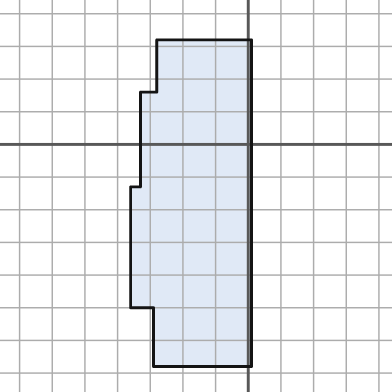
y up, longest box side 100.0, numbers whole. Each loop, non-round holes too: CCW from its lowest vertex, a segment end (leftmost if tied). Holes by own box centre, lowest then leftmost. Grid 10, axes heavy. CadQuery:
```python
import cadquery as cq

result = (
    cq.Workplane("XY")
    .moveTo(-29.0, -68.0)
    .lineTo(1.0, -68.0)
    .lineTo(1.0, 32.0)
    .lineTo(-28.0, 32.0)
    .lineTo(-28.0, 16.0)
    .lineTo(-33.0, 16.0)
    .lineTo(-33.0, -13.0)
    .lineTo(-36.0, -13.0)
    .lineTo(-36.0, -50.0)
    .lineTo(-29.0, -50.0)
    .close()
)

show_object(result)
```